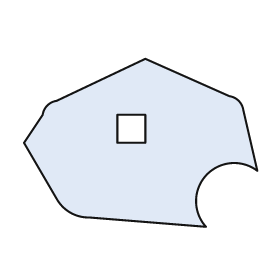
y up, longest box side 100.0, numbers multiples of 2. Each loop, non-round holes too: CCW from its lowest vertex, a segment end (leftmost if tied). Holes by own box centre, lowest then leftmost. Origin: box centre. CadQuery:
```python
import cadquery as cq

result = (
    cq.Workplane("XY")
    .moveTo(28.0, -36.0)
    .threePointArc((28.0, -14.0), (50.0, -12.0))
    .lineTo(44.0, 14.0)
    .threePointArc((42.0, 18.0), (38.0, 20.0))
    .lineTo(2.0, 36.0)
    .lineTo(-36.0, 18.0)
    .threePointArc((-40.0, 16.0), (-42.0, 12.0))
    .lineTo(-50.0, 0.0)
    .lineTo(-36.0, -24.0)
    .threePointArc((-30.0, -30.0), (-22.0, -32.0))
    .close()
    .moveTo(-10.0, 0.0)
    .lineTo(2.0, 0.0)
    .lineTo(2.0, 12.0)
    .lineTo(-10.0, 12.0)
    .close()
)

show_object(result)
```